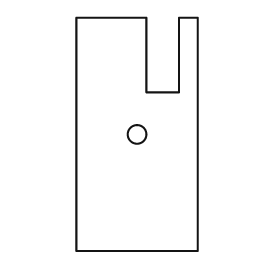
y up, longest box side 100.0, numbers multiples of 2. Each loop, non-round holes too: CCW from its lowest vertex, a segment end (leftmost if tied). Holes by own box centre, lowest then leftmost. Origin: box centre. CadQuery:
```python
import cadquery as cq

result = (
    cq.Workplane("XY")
    .moveTo(-26.0, -50.0)
    .lineTo(26.0, -50.0)
    .lineTo(26.0, 50.0)
    .lineTo(18.0, 50.0)
    .lineTo(18.0, 18.0)
    .lineTo(4.0, 18.0)
    .lineTo(4.0, 50.0)
    .lineTo(-26.0, 50.0)
    .close()
    .moveTo(0.0, 0.0)
    .circle(4.0)
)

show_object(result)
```